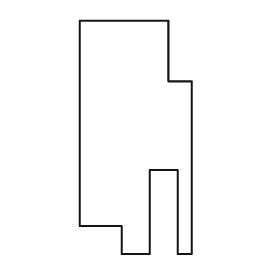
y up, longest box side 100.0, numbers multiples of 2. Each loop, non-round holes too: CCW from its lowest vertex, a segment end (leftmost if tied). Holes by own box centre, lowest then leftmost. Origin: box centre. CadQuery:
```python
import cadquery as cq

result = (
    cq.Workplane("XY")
    .moveTo(-6.0, -50.0)
    .lineTo(6.0, -50.0)
    .lineTo(6.0, -14.0)
    .lineTo(18.0, -14.0)
    .lineTo(18.0, -50.0)
    .lineTo(24.0, -50.0)
    .lineTo(24.0, 24.0)
    .lineTo(14.0, 24.0)
    .lineTo(14.0, 50.0)
    .lineTo(-24.0, 50.0)
    .lineTo(-24.0, -38.0)
    .lineTo(-6.0, -38.0)
    .close()
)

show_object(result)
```